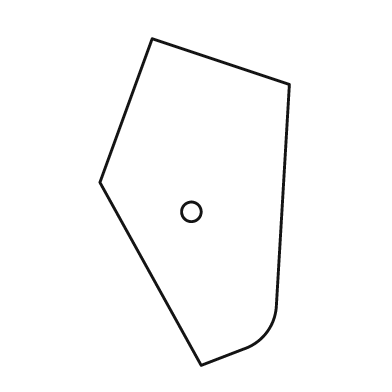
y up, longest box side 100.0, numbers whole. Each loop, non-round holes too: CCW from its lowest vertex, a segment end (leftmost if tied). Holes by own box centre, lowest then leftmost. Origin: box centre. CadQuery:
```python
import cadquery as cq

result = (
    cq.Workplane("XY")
    .moveTo(2.0, -50.0)
    .lineTo(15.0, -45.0)
    .threePointArc((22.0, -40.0), (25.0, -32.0))
    .lineTo(29.0, 36.0)
    .lineTo(-13.0, 50.0)
    .lineTo(-29.0, 6.0)
    .close()
    .moveTo(-1.0, -3.0)
    .circle(3.0)
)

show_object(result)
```